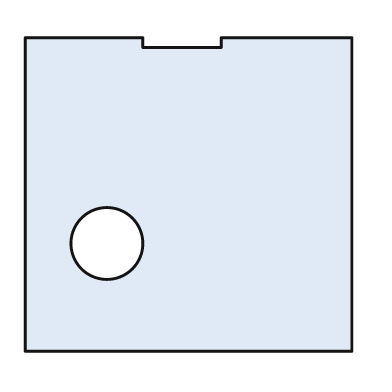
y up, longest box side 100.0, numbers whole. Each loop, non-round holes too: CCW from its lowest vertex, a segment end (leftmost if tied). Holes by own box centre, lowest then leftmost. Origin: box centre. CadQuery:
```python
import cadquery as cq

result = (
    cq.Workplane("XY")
    .moveTo(-50.0, -48.0)
    .lineTo(50.0, -48.0)
    .lineTo(50.0, 48.0)
    .lineTo(10.0, 48.0)
    .lineTo(10.0, 45.0)
    .lineTo(-14.0, 45.0)
    .lineTo(-14.0, 48.0)
    .lineTo(-50.0, 48.0)
    .close()
    .moveTo(-25.0, -15.0)
    .circle(11.0)
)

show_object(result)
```